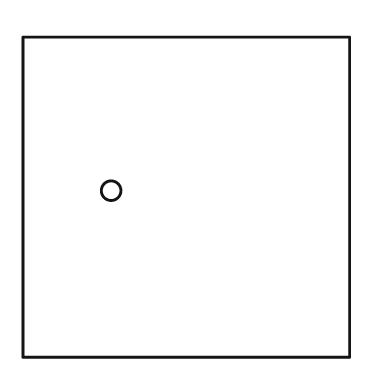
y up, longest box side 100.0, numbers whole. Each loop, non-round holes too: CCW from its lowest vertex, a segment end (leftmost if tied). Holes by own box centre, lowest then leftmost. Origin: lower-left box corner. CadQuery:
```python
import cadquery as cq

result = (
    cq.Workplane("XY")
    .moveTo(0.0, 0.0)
    .lineTo(100.0, 0.0)
    .lineTo(100.0, 98.0)
    .lineTo(0.0, 98.0)
    .close()
    .moveTo(27.0, 51.0)
    .circle(3.0)
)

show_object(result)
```